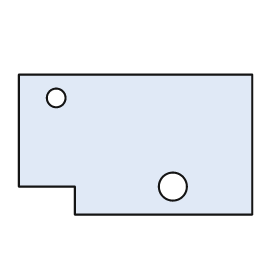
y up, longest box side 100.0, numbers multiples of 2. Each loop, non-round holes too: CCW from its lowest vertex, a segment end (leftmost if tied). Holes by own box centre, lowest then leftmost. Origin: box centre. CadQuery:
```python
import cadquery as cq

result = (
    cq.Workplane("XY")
    .moveTo(-26.0, -30.0)
    .lineTo(50.0, -30.0)
    .lineTo(50.0, 30.0)
    .lineTo(-50.0, 30.0)
    .lineTo(-50.0, -18.0)
    .lineTo(-26.0, -18.0)
    .close()
    .moveTo(16.0, -18.0)
    .circle(6.0)
    .moveTo(-34.0, 20.0)
    .circle(4.0)
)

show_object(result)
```